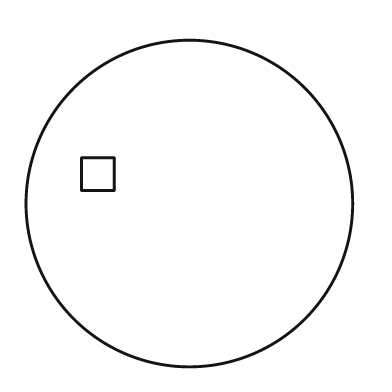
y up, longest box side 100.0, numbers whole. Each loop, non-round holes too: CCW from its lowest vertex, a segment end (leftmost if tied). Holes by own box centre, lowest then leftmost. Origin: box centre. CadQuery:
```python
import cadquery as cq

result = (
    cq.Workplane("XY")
    .moveTo(0.0, 0.0)
    .circle(50.0)
    .moveTo(-33.0, 4.0)
    .lineTo(-23.0, 4.0)
    .lineTo(-23.0, 14.0)
    .lineTo(-33.0, 14.0)
    .close()
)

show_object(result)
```